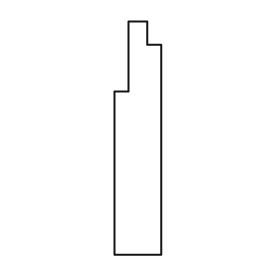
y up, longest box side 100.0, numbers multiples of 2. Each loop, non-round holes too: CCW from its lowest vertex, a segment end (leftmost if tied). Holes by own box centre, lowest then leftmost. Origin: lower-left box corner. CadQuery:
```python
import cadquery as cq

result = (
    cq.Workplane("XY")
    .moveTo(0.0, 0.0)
    .lineTo(20.0, 0.0)
    .lineTo(20.0, 90.0)
    .lineTo(14.0, 90.0)
    .lineTo(14.0, 100.0)
    .lineTo(6.0, 100.0)
    .lineTo(6.0, 70.0)
    .lineTo(0.0, 70.0)
    .close()
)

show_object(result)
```